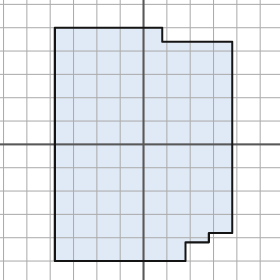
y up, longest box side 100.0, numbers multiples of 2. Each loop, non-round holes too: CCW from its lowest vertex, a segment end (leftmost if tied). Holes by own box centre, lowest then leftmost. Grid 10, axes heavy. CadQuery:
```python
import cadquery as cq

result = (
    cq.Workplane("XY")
    .moveTo(-38.0, -50.0)
    .lineTo(18.0, -50.0)
    .lineTo(18.0, -42.0)
    .lineTo(28.0, -42.0)
    .lineTo(28.0, -38.0)
    .lineTo(38.0, -38.0)
    .lineTo(38.0, 44.0)
    .lineTo(8.0, 44.0)
    .lineTo(8.0, 50.0)
    .lineTo(-38.0, 50.0)
    .close()
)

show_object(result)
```